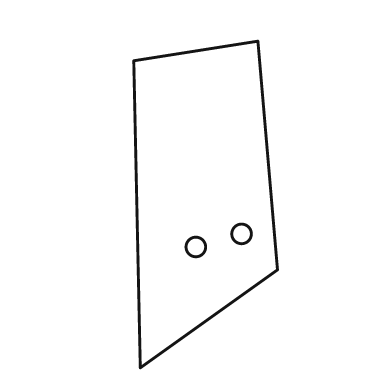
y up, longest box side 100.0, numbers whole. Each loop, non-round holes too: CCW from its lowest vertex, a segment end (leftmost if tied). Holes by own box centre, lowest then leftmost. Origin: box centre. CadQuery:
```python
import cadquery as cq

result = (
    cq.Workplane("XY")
    .moveTo(-20.0, -50.0)
    .lineTo(22.0, -20.0)
    .lineTo(16.0, 50.0)
    .lineTo(-22.0, 44.0)
    .close()
    .moveTo(-3.0, -13.0)
    .circle(3.0)
    .moveTo(11.0, -9.0)
    .circle(3.0)
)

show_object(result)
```